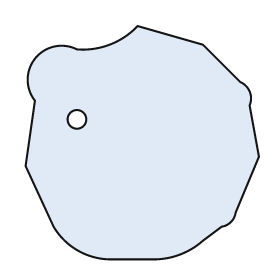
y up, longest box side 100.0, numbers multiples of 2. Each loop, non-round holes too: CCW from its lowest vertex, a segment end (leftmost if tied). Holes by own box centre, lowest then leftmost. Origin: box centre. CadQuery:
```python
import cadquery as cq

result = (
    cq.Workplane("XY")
    .moveTo(-14.0, -50.0)
    .lineTo(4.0, -50.0)
    .threePointArc((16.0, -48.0), (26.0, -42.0))
    .lineTo(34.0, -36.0)
    .threePointArc((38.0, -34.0), (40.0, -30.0))
    .lineTo(50.0, -6.0)
    .lineTo(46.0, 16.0)
    .threePointArc((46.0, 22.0), (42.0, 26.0))
    .lineTo(26.0, 42.0)
    .lineTo(-2.0, 50.0)
    .threePointArc((-14.0, 42.0), (-28.0, 40.0))
    .threePointArc((-46.0, 36.0), (-46.0, 18.0))
    .lineTo(-50.0, -10.0)
    .lineTo(-38.0, -36.0)
    .threePointArc((-28.0, -46.0), (-14.0, -50.0))
    .close()
    .moveTo(-28.0, 10.0)
    .circle(4.0)
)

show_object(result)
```